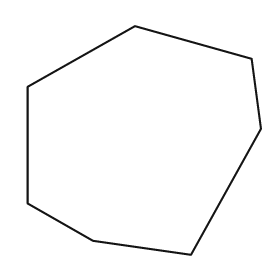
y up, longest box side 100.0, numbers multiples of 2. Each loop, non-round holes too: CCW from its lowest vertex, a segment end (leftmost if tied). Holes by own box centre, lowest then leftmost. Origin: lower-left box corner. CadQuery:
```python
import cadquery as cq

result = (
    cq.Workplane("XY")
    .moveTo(70.0, 0.0)
    .lineTo(100.0, 54.0)
    .lineTo(96.0, 84.0)
    .lineTo(46.0, 98.0)
    .lineTo(0.0, 72.0)
    .lineTo(0.0, 22.0)
    .lineTo(28.0, 6.0)
    .close()
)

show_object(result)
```